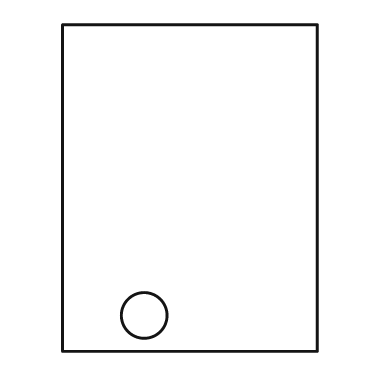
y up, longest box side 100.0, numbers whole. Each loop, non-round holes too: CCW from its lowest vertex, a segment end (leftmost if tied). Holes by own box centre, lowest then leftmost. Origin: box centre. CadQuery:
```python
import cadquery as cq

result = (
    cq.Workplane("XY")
    .moveTo(-39.0, -50.0)
    .lineTo(39.0, -50.0)
    .lineTo(39.0, 50.0)
    .lineTo(-39.0, 50.0)
    .close()
    .moveTo(-14.0, -39.0)
    .circle(7.0)
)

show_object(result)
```